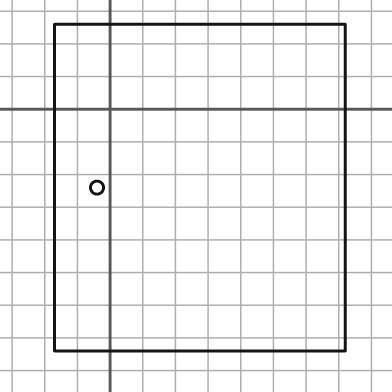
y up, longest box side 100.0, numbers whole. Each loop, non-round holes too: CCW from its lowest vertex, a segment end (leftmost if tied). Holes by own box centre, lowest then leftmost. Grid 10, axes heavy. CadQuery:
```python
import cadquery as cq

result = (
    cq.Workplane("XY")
    .moveTo(-17.0, -74.0)
    .lineTo(72.0, -74.0)
    .lineTo(72.0, 26.0)
    .lineTo(-17.0, 26.0)
    .close()
    .moveTo(-4.0, -24.0)
    .circle(2.0)
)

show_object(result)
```